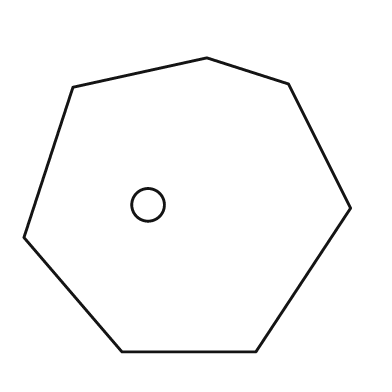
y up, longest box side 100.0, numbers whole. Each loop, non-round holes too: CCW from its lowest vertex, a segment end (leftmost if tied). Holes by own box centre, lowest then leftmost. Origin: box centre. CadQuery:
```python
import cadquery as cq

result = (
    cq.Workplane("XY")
    .moveTo(-20.0, -45.0)
    .lineTo(21.0, -45.0)
    .lineTo(50.0, -1.0)
    .lineTo(31.0, 37.0)
    .lineTo(6.0, 45.0)
    .lineTo(-35.0, 36.0)
    .lineTo(-50.0, -10.0)
    .close()
    .moveTo(-12.0, 0.0)
    .circle(5.0)
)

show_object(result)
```